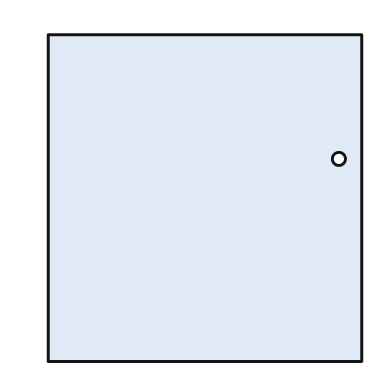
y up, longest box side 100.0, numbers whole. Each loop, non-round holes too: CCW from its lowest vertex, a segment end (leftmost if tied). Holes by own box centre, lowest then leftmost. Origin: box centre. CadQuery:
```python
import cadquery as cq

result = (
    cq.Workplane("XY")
    .moveTo(-48.0, -50.0)
    .lineTo(48.0, -50.0)
    .lineTo(48.0, 50.0)
    .lineTo(-48.0, 50.0)
    .close()
    .moveTo(41.0, 12.0)
    .circle(2.0)
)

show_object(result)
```